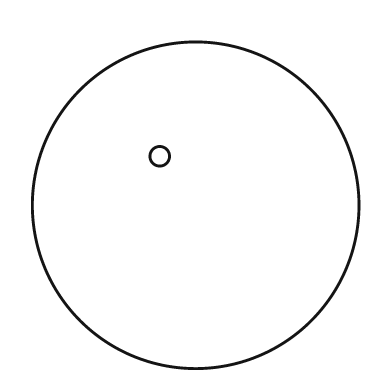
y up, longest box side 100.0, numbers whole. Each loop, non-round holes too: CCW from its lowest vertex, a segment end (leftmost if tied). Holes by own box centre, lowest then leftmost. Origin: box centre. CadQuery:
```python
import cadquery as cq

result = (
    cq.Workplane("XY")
    .moveTo(0.0, 0.0)
    .circle(50.0)
    .moveTo(-11.0, 15.0)
    .circle(3.0)
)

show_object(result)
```